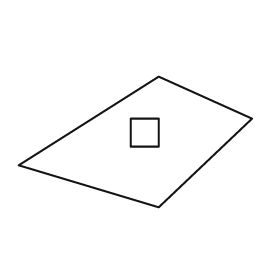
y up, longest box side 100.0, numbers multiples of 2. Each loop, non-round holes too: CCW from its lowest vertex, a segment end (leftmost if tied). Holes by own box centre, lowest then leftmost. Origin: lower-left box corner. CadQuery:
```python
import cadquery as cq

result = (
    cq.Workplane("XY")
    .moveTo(60.0, 0.0)
    .lineTo(100.0, 38.0)
    .lineTo(60.0, 56.0)
    .lineTo(0.0, 18.0)
    .close()
    .moveTo(48.0, 26.0)
    .lineTo(60.0, 26.0)
    .lineTo(60.0, 38.0)
    .lineTo(48.0, 38.0)
    .close()
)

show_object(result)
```